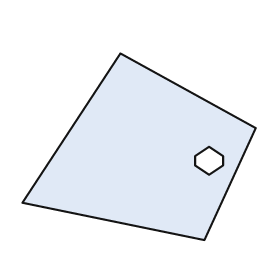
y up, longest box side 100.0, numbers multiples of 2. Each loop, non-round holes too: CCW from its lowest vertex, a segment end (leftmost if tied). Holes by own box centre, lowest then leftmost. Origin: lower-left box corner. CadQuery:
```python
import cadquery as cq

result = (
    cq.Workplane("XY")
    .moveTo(78.0, 0.0)
    .lineTo(100.0, 48.0)
    .lineTo(42.0, 80.0)
    .lineTo(0.0, 16.0)
    .close()
    .moveTo(80.0, 28.0)
    .lineTo(86.0, 32.0)
    .lineTo(86.0, 36.0)
    .lineTo(80.0, 40.0)
    .lineTo(74.0, 36.0)
    .lineTo(74.0, 32.0)
    .close()
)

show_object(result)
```